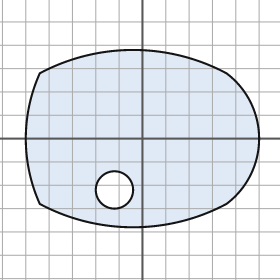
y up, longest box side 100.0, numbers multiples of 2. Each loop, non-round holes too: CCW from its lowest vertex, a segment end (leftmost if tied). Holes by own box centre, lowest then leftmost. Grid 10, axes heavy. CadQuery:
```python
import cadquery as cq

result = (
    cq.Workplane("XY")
    .moveTo(-44.0, -28.0)
    .threePointArc((-4.0, -38.0), (36.0, -28.0))
    .threePointArc((50.0, 0.0), (36.0, 28.0))
    .threePointArc((-4.0, 38.0), (-44.0, 28.0))
    .threePointArc((-50.0, 0.0), (-44.0, -28.0))
    .close()
    .moveTo(-12.0, -22.0)
    .circle(8.0)
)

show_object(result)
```